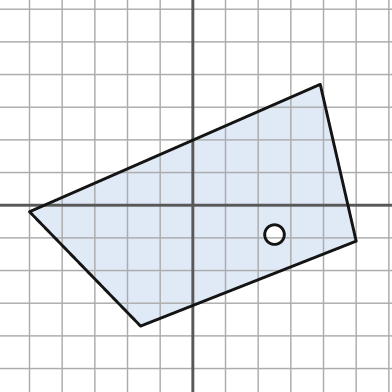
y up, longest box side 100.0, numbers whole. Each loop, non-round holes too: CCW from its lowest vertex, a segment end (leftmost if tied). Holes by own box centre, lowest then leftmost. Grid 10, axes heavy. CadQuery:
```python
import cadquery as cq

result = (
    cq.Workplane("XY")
    .moveTo(-16.0, -37.0)
    .lineTo(50.0, -11.0)
    .lineTo(39.0, 37.0)
    .lineTo(-50.0, -2.0)
    .close()
    .moveTo(25.0, -9.0)
    .circle(3.0)
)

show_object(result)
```